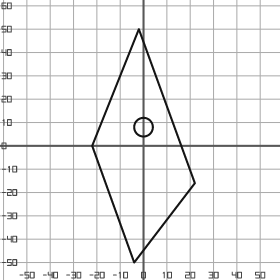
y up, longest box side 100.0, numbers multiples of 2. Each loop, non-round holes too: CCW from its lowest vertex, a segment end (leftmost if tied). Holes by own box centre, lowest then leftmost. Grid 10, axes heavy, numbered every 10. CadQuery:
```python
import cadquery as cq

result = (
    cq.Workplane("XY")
    .moveTo(-4.0, -50.0)
    .lineTo(22.0, -16.0)
    .lineTo(-2.0, 50.0)
    .lineTo(-22.0, 0.0)
    .close()
    .moveTo(0.0, 8.0)
    .circle(4.0)
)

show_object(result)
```